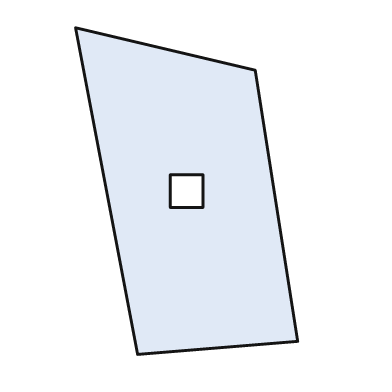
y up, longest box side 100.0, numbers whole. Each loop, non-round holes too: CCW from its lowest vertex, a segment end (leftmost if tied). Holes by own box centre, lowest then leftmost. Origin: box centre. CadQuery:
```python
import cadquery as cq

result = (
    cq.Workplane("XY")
    .moveTo(-15.0, -50.0)
    .lineTo(34.0, -46.0)
    .lineTo(21.0, 37.0)
    .lineTo(-34.0, 50.0)
    .close()
    .moveTo(-5.0, -5.0)
    .lineTo(5.0, -5.0)
    .lineTo(5.0, 5.0)
    .lineTo(-5.0, 5.0)
    .close()
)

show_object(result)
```